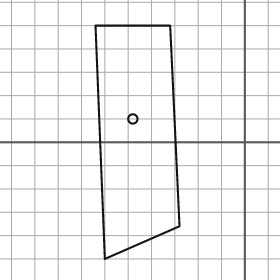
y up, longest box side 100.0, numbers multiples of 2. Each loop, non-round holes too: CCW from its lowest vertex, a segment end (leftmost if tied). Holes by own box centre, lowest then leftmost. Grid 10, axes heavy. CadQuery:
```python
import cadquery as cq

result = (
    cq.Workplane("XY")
    .moveTo(-60.0, -50.0)
    .lineTo(-28.0, -36.0)
    .lineTo(-32.0, 50.0)
    .lineTo(-64.0, 50.0)
    .close()
    .moveTo(-48.0, 10.0)
    .circle(2.0)
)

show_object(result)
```